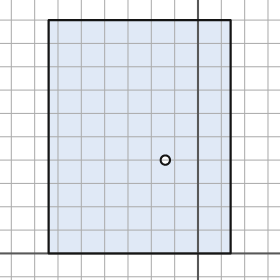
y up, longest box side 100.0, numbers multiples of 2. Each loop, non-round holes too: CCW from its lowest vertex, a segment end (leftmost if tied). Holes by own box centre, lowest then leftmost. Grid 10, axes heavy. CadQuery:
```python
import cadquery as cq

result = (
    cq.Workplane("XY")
    .moveTo(-64.0, 0.0)
    .lineTo(14.0, 0.0)
    .lineTo(14.0, 100.0)
    .lineTo(-64.0, 100.0)
    .close()
    .moveTo(-14.0, 40.0)
    .circle(2.0)
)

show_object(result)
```